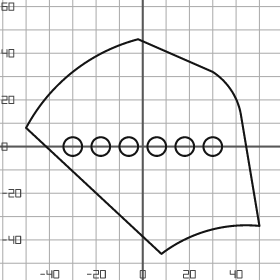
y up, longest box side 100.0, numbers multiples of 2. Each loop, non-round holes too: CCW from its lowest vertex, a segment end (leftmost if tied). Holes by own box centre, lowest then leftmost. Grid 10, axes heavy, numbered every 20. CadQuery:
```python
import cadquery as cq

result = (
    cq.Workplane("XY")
    .moveTo(8.0, -46.0)
    .threePointArc((28.0, -36.0), (50.0, -34.0))
    .lineTo(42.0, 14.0)
    .threePointArc((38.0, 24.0), (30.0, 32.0))
    .lineTo(-2.0, 46.0)
    .threePointArc((-30.0, 32.0), (-50.0, 8.0))
    .close()
    .moveTo(-30.0, 0.0)
    .circle(4.0)
    .moveTo(-18.0, 0.0)
    .circle(4.0)
    .moveTo(-6.0, 0.0)
    .circle(4.0)
    .moveTo(6.0, 0.0)
    .circle(4.0)
    .moveTo(18.0, 0.0)
    .circle(4.0)
    .moveTo(30.0, 0.0)
    .circle(4.0)
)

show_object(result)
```